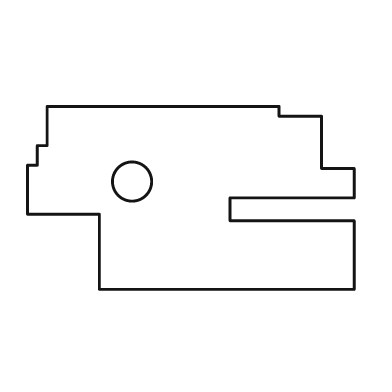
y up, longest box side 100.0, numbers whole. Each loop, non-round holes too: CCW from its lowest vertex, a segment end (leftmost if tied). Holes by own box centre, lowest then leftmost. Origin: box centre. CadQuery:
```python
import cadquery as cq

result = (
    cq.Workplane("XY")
    .moveTo(-28.0, -28.0)
    .lineTo(50.0, -28.0)
    .lineTo(50.0, -7.0)
    .lineTo(12.0, -7.0)
    .lineTo(12.0, 0.0)
    .lineTo(50.0, 0.0)
    .lineTo(50.0, 9.0)
    .lineTo(40.0, 9.0)
    .lineTo(40.0, 25.0)
    .lineTo(27.0, 25.0)
    .lineTo(27.0, 28.0)
    .lineTo(-44.0, 28.0)
    .lineTo(-44.0, 16.0)
    .lineTo(-47.0, 16.0)
    .lineTo(-47.0, 10.0)
    .lineTo(-50.0, 10.0)
    .lineTo(-50.0, -5.0)
    .lineTo(-28.0, -5.0)
    .close()
    .moveTo(-18.0, 5.0)
    .circle(6.0)
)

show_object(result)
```